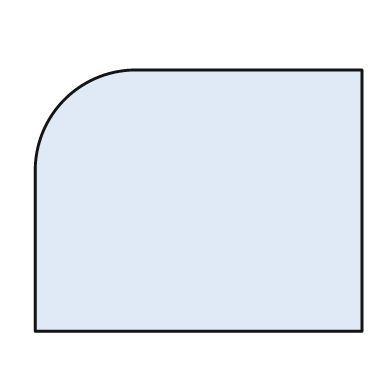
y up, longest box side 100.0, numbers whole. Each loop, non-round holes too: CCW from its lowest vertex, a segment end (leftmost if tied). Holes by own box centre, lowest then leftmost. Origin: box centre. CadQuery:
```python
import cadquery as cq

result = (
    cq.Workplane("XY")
    .moveTo(-50.0, -40.0)
    .lineTo(50.0, -40.0)
    .lineTo(50.0, 40.0)
    .lineTo(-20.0, 40.0)
    .threePointArc((-41.0, 31.0), (-50.0, 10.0))
    .close()
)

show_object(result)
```